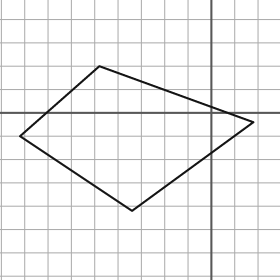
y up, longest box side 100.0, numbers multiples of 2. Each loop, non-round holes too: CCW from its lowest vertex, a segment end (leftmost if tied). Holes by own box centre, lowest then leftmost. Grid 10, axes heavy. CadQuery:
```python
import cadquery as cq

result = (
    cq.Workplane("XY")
    .moveTo(-34.0, -42.0)
    .lineTo(18.0, -4.0)
    .lineTo(-48.0, 20.0)
    .lineTo(-82.0, -10.0)
    .close()
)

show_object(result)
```